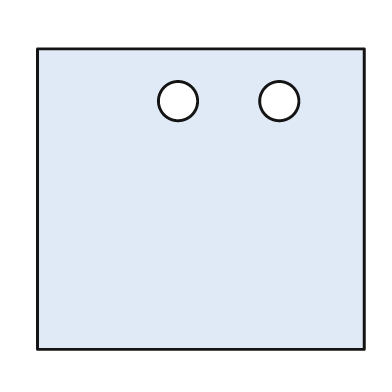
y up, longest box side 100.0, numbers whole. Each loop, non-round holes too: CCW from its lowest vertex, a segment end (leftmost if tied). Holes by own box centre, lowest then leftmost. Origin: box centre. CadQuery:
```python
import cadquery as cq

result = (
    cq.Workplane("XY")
    .moveTo(-50.0, -46.0)
    .lineTo(50.0, -46.0)
    .lineTo(50.0, 46.0)
    .lineTo(-50.0, 46.0)
    .close()
    .moveTo(-7.0, 30.0)
    .circle(6.0)
    .moveTo(24.0, 30.0)
    .circle(6.0)
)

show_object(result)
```